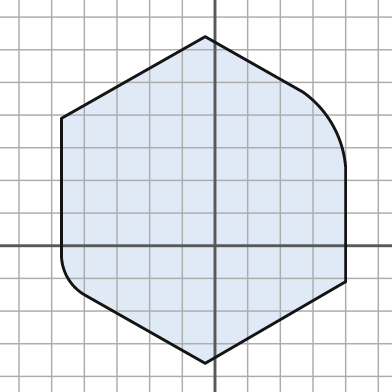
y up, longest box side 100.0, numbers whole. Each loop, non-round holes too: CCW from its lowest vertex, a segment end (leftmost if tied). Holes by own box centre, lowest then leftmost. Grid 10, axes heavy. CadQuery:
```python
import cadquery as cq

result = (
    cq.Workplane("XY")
    .moveTo(-3.0, -36.0)
    .lineTo(40.0, -11.0)
    .lineTo(40.0, 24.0)
    .threePointArc((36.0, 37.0), (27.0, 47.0))
    .lineTo(-3.0, 64.0)
    .lineTo(-47.0, 39.0)
    .lineTo(-47.0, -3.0)
    .threePointArc((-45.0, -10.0), (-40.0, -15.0))
    .close()
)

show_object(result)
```